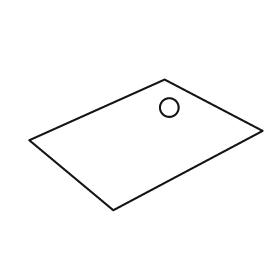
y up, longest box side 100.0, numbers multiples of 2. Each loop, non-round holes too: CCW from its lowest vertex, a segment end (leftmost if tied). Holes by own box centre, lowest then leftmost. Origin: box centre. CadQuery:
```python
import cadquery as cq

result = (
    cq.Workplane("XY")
    .moveTo(-14.0, -28.0)
    .lineTo(50.0, 6.0)
    .lineTo(8.0, 28.0)
    .lineTo(-50.0, 2.0)
    .close()
    .moveTo(10.0, 16.0)
    .circle(4.0)
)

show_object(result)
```